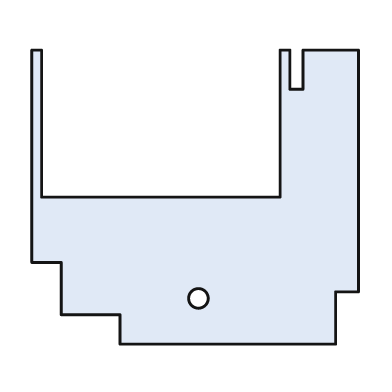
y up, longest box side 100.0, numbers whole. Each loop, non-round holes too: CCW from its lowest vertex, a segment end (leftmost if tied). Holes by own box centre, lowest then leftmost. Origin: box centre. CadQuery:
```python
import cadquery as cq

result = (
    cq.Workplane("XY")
    .moveTo(-23.0, -45.0)
    .lineTo(43.0, -45.0)
    .lineTo(43.0, -29.0)
    .lineTo(50.0, -29.0)
    .lineTo(50.0, 45.0)
    .lineTo(33.0, 45.0)
    .lineTo(33.0, 33.0)
    .lineTo(29.0, 33.0)
    .lineTo(29.0, 45.0)
    .lineTo(26.0, 45.0)
    .lineTo(26.0, 0.0)
    .lineTo(-47.0, 0.0)
    .lineTo(-47.0, 45.0)
    .lineTo(-50.0, 45.0)
    .lineTo(-50.0, -20.0)
    .lineTo(-41.0, -20.0)
    .lineTo(-41.0, -36.0)
    .lineTo(-23.0, -36.0)
    .close()
    .moveTo(1.0, -31.0)
    .circle(3.0)
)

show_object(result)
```